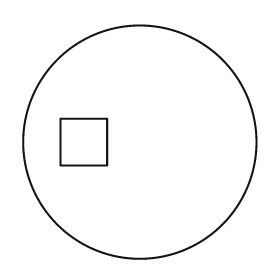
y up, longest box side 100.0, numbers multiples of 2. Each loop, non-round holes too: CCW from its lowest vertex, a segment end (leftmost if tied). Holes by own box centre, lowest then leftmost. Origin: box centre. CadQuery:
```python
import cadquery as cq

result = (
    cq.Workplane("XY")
    .moveTo(0.0, 0.0)
    .circle(50.0)
    .moveTo(-34.0, -10.0)
    .lineTo(-14.0, -10.0)
    .lineTo(-14.0, 10.0)
    .lineTo(-34.0, 10.0)
    .close()
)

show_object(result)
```